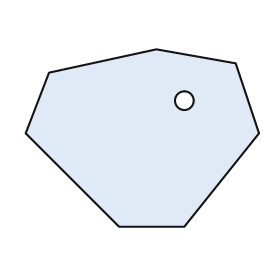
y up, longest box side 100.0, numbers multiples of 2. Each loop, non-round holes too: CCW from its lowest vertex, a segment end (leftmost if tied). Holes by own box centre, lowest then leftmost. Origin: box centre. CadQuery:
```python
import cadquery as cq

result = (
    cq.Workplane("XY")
    .moveTo(-10.0, -38.0)
    .lineTo(18.0, -38.0)
    .lineTo(50.0, 2.0)
    .lineTo(40.0, 32.0)
    .lineTo(6.0, 38.0)
    .lineTo(-40.0, 28.0)
    .lineTo(-50.0, 2.0)
    .close()
    .moveTo(18.0, 16.0)
    .circle(4.0)
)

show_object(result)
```